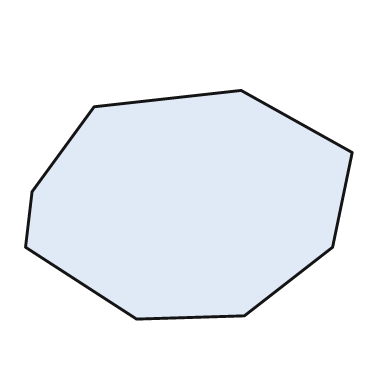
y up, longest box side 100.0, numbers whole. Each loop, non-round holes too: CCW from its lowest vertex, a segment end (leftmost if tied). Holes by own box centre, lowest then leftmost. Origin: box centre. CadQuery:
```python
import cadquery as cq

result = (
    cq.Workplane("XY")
    .moveTo(-16.0, -35.0)
    .lineTo(17.0, -34.0)
    .lineTo(44.0, -13.0)
    .lineTo(50.0, 16.0)
    .lineTo(16.0, 35.0)
    .lineTo(-29.0, 30.0)
    .lineTo(-48.0, 4.0)
    .lineTo(-50.0, -13.0)
    .close()
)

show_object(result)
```